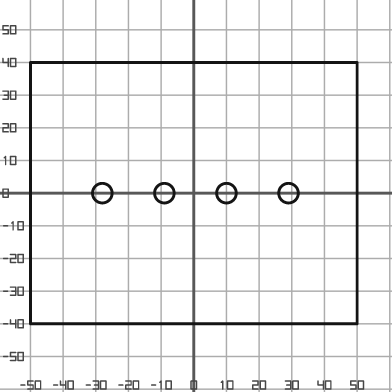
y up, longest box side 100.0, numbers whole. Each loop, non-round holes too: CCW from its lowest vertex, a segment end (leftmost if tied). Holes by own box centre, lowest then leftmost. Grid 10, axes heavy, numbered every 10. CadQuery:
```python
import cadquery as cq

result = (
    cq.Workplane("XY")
    .moveTo(-50.0, -40.0)
    .lineTo(50.0, -40.0)
    .lineTo(50.0, 40.0)
    .lineTo(-50.0, 40.0)
    .close()
    .moveTo(-28.0, 0.0)
    .circle(3.0)
    .moveTo(-9.0, 0.0)
    .circle(3.0)
    .moveTo(10.0, 0.0)
    .circle(3.0)
    .moveTo(29.0, 0.0)
    .circle(3.0)
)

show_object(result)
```